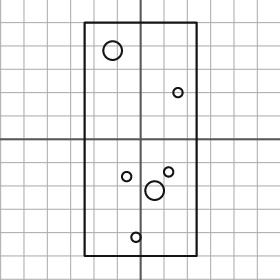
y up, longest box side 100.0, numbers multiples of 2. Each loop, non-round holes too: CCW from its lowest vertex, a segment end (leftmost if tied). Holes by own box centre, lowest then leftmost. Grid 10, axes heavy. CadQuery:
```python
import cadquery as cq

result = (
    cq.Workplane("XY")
    .moveTo(-24.0, -50.0)
    .lineTo(24.0, -50.0)
    .lineTo(24.0, 50.0)
    .lineTo(-24.0, 50.0)
    .close()
    .moveTo(-2.0, -42.0)
    .circle(2.0)
    .moveTo(6.0, -22.0)
    .circle(4.0)
    .moveTo(-6.0, -16.0)
    .circle(2.0)
    .moveTo(12.0, -14.0)
    .circle(2.0)
    .moveTo(16.0, 20.0)
    .circle(2.0)
    .moveTo(-12.0, 38.0)
    .circle(4.0)
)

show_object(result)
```